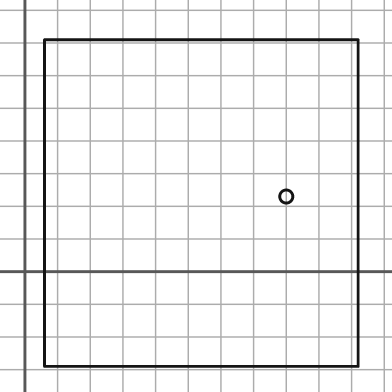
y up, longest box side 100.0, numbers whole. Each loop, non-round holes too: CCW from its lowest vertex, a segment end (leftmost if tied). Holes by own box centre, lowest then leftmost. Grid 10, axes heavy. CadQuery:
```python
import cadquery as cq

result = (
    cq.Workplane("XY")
    .moveTo(6.0, -29.0)
    .lineTo(102.0, -29.0)
    .lineTo(102.0, 71.0)
    .lineTo(6.0, 71.0)
    .close()
    .moveTo(80.0, 23.0)
    .circle(2.0)
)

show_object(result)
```